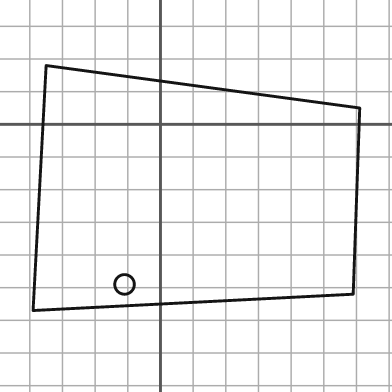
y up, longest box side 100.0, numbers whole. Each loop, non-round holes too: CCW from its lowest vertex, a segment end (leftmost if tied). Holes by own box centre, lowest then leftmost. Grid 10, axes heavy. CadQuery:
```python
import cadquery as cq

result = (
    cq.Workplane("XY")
    .moveTo(-39.0, -57.0)
    .lineTo(59.0, -52.0)
    .lineTo(61.0, 5.0)
    .lineTo(-35.0, 18.0)
    .close()
    .moveTo(-11.0, -49.0)
    .circle(3.0)
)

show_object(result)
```